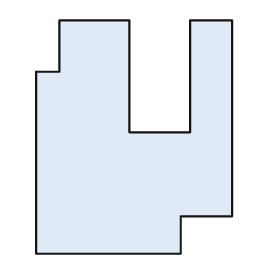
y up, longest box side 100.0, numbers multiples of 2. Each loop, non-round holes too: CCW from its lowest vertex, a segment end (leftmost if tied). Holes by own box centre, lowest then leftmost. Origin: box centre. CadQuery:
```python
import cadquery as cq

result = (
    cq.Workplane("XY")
    .moveTo(-42.0, -50.0)
    .lineTo(20.0, -50.0)
    .lineTo(20.0, -34.0)
    .lineTo(42.0, -34.0)
    .lineTo(42.0, 50.0)
    .lineTo(24.0, 50.0)
    .lineTo(24.0, 2.0)
    .lineTo(-2.0, 2.0)
    .lineTo(-2.0, 50.0)
    .lineTo(-32.0, 50.0)
    .lineTo(-32.0, 28.0)
    .lineTo(-42.0, 28.0)
    .close()
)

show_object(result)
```